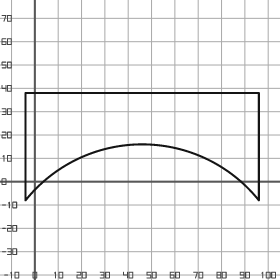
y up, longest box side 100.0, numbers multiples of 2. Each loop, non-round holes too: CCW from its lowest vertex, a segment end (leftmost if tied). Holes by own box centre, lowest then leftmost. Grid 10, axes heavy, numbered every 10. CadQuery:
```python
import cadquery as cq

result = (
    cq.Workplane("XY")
    .moveTo(-4.0, -8.0)
    .threePointArc((46.0, 16.0), (96.0, -8.0))
    .lineTo(96.0, 38.0)
    .lineTo(-4.0, 38.0)
    .close()
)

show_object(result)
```